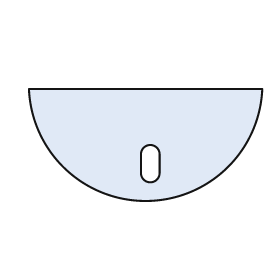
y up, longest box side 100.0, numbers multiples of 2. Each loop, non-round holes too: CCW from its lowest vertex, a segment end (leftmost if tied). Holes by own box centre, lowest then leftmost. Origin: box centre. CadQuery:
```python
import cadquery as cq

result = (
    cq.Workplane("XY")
    .moveTo(-50.0, 24.0)
    .threePointArc((0.0, -24.0), (50.0, 24.0))
    .close()
    .moveTo(-2.0, -12.0)
    .threePointArc((2.0, -16.0), (6.0, -12.0))
    .lineTo(6.0, -4.0)
    .threePointArc((2.0, 0.0), (-2.0, -4.0))
    .close()
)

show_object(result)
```